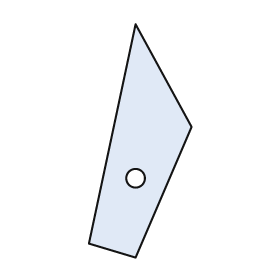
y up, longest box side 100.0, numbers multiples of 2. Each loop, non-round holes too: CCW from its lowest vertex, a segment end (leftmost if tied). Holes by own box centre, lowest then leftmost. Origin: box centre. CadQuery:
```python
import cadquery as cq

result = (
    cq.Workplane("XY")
    .moveTo(-2.0, -50.0)
    .lineTo(22.0, 6.0)
    .lineTo(-2.0, 50.0)
    .lineTo(-22.0, -44.0)
    .close()
    .moveTo(-2.0, -16.0)
    .circle(4.0)
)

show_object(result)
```